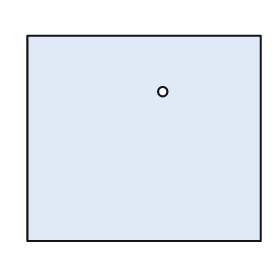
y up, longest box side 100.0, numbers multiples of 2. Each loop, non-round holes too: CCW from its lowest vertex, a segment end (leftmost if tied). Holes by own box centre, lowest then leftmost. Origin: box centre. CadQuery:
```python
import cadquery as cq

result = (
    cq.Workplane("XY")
    .moveTo(-50.0, -44.0)
    .lineTo(50.0, -44.0)
    .lineTo(50.0, 44.0)
    .lineTo(-50.0, 44.0)
    .close()
    .moveTo(8.0, 20.0)
    .circle(2.0)
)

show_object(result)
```